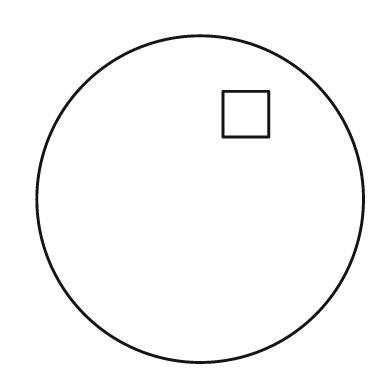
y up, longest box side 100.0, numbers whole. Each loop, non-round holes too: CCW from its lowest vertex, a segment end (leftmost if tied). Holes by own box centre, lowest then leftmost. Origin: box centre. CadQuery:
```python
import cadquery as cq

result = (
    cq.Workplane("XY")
    .moveTo(0.0, 0.0)
    .circle(50.0)
    .moveTo(7.0, 19.0)
    .lineTo(21.0, 19.0)
    .lineTo(21.0, 33.0)
    .lineTo(7.0, 33.0)
    .close()
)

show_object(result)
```